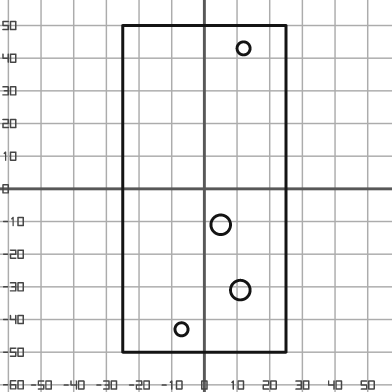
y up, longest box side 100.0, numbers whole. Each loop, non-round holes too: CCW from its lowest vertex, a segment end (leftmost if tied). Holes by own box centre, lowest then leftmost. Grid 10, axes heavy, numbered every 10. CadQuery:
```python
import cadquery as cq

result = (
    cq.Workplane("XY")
    .moveTo(-25.0, -50.0)
    .lineTo(25.0, -50.0)
    .lineTo(25.0, 50.0)
    .lineTo(-25.0, 50.0)
    .close()
    .moveTo(-7.0, -43.0)
    .circle(2.0)
    .moveTo(11.0, -31.0)
    .circle(3.0)
    .moveTo(5.0, -11.0)
    .circle(3.0)
    .moveTo(12.0, 43.0)
    .circle(2.0)
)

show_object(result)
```